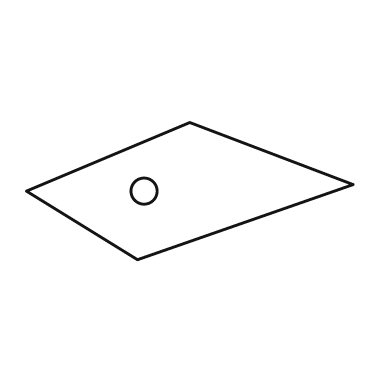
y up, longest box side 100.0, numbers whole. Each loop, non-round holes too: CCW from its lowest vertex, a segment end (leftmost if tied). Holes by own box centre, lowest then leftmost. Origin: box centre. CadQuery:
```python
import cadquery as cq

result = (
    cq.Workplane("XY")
    .moveTo(-16.0, -21.0)
    .lineTo(50.0, 2.0)
    .lineTo(0.0, 21.0)
    .lineTo(-50.0, 0.0)
    .close()
    .moveTo(-14.0, 0.0)
    .circle(4.0)
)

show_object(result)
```